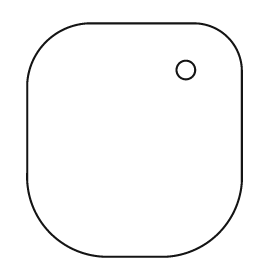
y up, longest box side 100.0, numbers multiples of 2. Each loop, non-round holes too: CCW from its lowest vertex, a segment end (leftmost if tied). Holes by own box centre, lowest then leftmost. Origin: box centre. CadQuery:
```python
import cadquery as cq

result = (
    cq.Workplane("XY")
    .moveTo(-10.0, -50.0)
    .lineTo(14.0, -50.0)
    .threePointArc((36.0, -40.0), (46.0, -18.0))
    .lineTo(46.0, 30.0)
    .threePointArc((40.0, 44.0), (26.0, 50.0))
    .lineTo(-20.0, 50.0)
    .threePointArc((-38.0, 42.0), (-46.0, 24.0))
    .lineTo(-46.0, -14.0)
    .threePointArc((-36.0, -40.0), (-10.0, -50.0))
    .close()
    .moveTo(22.0, 30.0)
    .circle(4.0)
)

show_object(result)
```